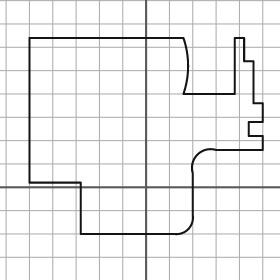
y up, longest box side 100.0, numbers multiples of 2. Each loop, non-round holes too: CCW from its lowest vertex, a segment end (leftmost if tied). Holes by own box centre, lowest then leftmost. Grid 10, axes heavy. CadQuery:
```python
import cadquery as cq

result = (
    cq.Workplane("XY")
    .moveTo(-28.0, -20.0)
    .lineTo(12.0, -20.0)
    .threePointArc((18.0, -18.0), (20.0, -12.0))
    .lineTo(20.0, 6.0)
    .threePointArc((22.0, 14.0), (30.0, 16.0))
    .lineTo(50.0, 16.0)
    .lineTo(50.0, 22.0)
    .lineTo(44.0, 22.0)
    .lineTo(44.0, 28.0)
    .lineTo(50.0, 28.0)
    .lineTo(50.0, 36.0)
    .lineTo(46.0, 36.0)
    .lineTo(46.0, 54.0)
    .lineTo(42.0, 54.0)
    .lineTo(42.0, 64.0)
    .lineTo(38.0, 64.0)
    .lineTo(38.0, 40.0)
    .lineTo(16.0, 40.0)
    .threePointArc((18.0, 52.0), (16.0, 64.0))
    .lineTo(-50.0, 64.0)
    .lineTo(-50.0, 2.0)
    .lineTo(-28.0, 2.0)
    .close()
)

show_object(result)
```